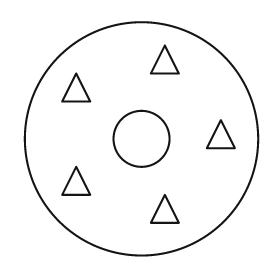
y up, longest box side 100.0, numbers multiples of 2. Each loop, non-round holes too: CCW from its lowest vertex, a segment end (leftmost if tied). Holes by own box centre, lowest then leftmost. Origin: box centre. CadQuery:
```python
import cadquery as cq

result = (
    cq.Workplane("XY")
    .moveTo(0.0, 0.0)
    .circle(50.0)
    .moveTo(4.0, -36.0)
    .lineTo(16.0, -36.0)
    .lineTo(10.0, -24.0)
    .close()
    .moveTo(-34.0, -24.0)
    .lineTo(-22.0, -24.0)
    .lineTo(-28.0, -12.0)
    .close()
    .moveTo(0.0, 0.0)
    .circle(12.0)
    .moveTo(28.0, -4.0)
    .lineTo(40.0, -4.0)
    .lineTo(34.0, 8.0)
    .close()
    .moveTo(-34.0, 16.0)
    .lineTo(-22.0, 16.0)
    .lineTo(-28.0, 28.0)
    .close()
    .moveTo(4.0, 28.0)
    .lineTo(16.0, 28.0)
    .lineTo(10.0, 40.0)
    .close()
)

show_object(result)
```